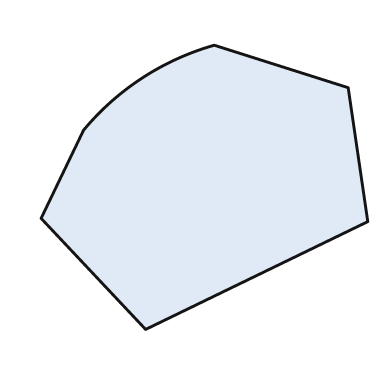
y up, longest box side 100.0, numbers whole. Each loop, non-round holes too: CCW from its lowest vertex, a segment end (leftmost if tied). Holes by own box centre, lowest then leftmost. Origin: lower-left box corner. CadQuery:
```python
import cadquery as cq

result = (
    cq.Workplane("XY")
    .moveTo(32.0, 0.0)
    .lineTo(100.0, 33.0)
    .lineTo(94.0, 74.0)
    .lineTo(53.0, 87.0)
    .threePointArc((31.0, 77.0), (13.0, 61.0))
    .lineTo(0.0, 34.0)
    .close()
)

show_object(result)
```